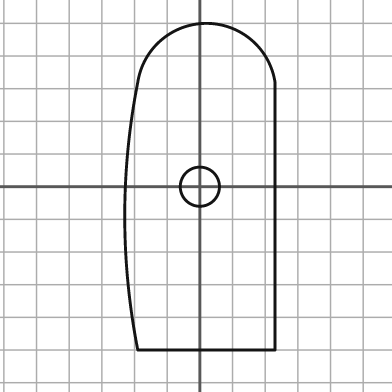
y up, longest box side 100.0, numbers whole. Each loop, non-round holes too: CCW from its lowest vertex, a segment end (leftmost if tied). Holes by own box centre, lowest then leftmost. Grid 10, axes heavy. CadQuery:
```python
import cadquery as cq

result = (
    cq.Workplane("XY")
    .moveTo(-19.0, -50.0)
    .lineTo(23.0, -50.0)
    .lineTo(23.0, 32.0)
    .threePointArc((2.0, 50.0), (-19.0, 32.0))
    .threePointArc((-23.0, -9.0), (-19.0, -50.0))
    .close()
    .moveTo(0.0, 0.0)
    .circle(6.0)
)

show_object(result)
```